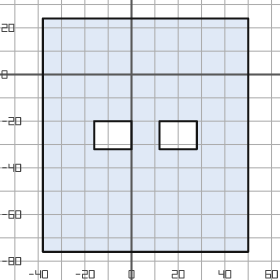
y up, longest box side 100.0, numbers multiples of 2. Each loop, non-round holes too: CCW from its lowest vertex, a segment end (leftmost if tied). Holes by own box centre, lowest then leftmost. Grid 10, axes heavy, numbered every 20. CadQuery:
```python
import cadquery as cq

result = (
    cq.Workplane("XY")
    .moveTo(-38.0, -76.0)
    .lineTo(50.0, -76.0)
    .lineTo(50.0, 24.0)
    .lineTo(-38.0, 24.0)
    .close()
    .moveTo(-16.0, -32.0)
    .lineTo(0.0, -32.0)
    .lineTo(0.0, -20.0)
    .lineTo(-16.0, -20.0)
    .close()
    .moveTo(12.0, -32.0)
    .lineTo(28.0, -32.0)
    .lineTo(28.0, -20.0)
    .lineTo(12.0, -20.0)
    .close()
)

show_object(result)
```